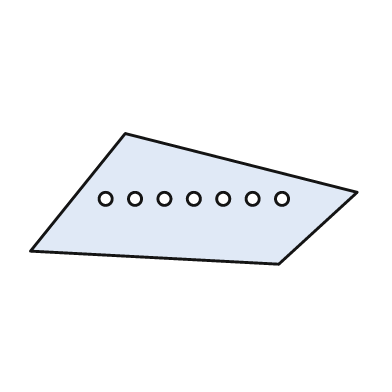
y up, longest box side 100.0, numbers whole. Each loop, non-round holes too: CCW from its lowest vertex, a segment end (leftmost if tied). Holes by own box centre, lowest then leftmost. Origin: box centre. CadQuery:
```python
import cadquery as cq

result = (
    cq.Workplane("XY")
    .moveTo(26.0, -20.0)
    .lineTo(50.0, 2.0)
    .lineTo(-21.0, 20.0)
    .lineTo(-50.0, -16.0)
    .close()
    .moveTo(-27.0, 0.0)
    .circle(2.0)
    .moveTo(-18.0, 0.0)
    .circle(2.0)
    .moveTo(-9.0, 0.0)
    .circle(2.0)
    .moveTo(0.0, 0.0)
    .circle(2.0)
    .moveTo(9.0, 0.0)
    .circle(2.0)
    .moveTo(18.0, 0.0)
    .circle(2.0)
    .moveTo(27.0, 0.0)
    .circle(2.0)
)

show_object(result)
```